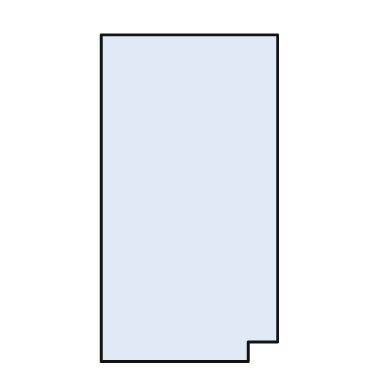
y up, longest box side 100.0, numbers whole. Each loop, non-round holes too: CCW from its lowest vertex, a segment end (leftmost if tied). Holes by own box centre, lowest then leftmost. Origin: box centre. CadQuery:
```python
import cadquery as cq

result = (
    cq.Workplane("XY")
    .moveTo(-27.0, -50.0)
    .lineTo(18.0, -50.0)
    .lineTo(18.0, -44.0)
    .lineTo(27.0, -44.0)
    .lineTo(27.0, 50.0)
    .lineTo(-27.0, 50.0)
    .close()
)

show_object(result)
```